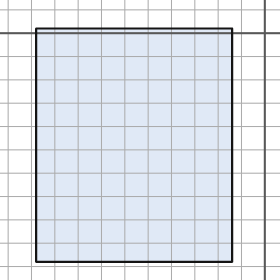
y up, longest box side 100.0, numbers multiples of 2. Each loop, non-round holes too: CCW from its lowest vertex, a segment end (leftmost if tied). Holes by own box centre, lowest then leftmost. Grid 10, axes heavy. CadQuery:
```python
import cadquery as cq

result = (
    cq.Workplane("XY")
    .moveTo(-98.0, -98.0)
    .lineTo(-14.0, -98.0)
    .lineTo(-14.0, 2.0)
    .lineTo(-98.0, 2.0)
    .close()
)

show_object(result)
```